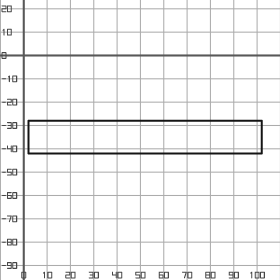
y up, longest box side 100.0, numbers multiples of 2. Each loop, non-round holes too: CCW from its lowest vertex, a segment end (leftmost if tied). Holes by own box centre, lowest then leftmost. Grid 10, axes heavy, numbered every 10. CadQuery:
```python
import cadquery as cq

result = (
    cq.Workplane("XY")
    .moveTo(2.0, -42.0)
    .lineTo(102.0, -42.0)
    .lineTo(102.0, -28.0)
    .lineTo(2.0, -28.0)
    .close()
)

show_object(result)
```